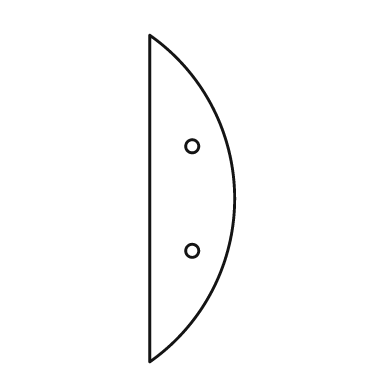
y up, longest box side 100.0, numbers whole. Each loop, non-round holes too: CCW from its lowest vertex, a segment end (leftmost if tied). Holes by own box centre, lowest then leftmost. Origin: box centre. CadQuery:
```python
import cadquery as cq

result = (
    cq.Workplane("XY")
    .moveTo(-13.0, -50.0)
    .threePointArc((13.0, 0.0), (-13.0, 50.0))
    .close()
    .moveTo(0.0, -16.0)
    .circle(2.0)
    .moveTo(0.0, 16.0)
    .circle(2.0)
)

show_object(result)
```